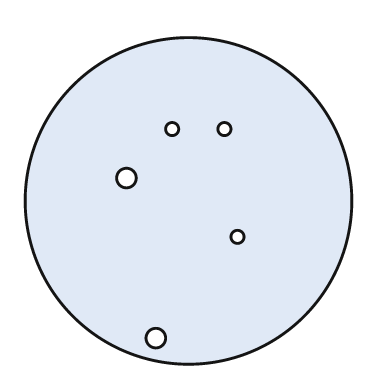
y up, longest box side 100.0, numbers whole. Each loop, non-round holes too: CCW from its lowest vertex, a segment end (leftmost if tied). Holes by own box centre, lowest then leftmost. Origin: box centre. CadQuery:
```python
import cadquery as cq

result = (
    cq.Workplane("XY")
    .moveTo(0.0, 0.0)
    .circle(50.0)
    .moveTo(-10.0, -42.0)
    .circle(3.0)
    .moveTo(15.0, -11.0)
    .circle(2.0)
    .moveTo(-19.0, 7.0)
    .circle(3.0)
    .moveTo(-5.0, 22.0)
    .circle(2.0)
    .moveTo(11.0, 22.0)
    .circle(2.0)
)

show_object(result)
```